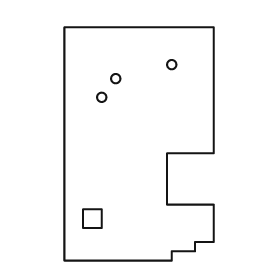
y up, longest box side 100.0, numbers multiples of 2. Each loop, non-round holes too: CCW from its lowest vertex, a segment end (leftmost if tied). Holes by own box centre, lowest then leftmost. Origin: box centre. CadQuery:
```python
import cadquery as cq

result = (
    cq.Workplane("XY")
    .moveTo(-32.0, -50.0)
    .lineTo(14.0, -50.0)
    .lineTo(14.0, -46.0)
    .lineTo(24.0, -46.0)
    .lineTo(24.0, -42.0)
    .lineTo(32.0, -42.0)
    .lineTo(32.0, -26.0)
    .lineTo(12.0, -26.0)
    .lineTo(12.0, -4.0)
    .lineTo(32.0, -4.0)
    .lineTo(32.0, 50.0)
    .lineTo(-32.0, 50.0)
    .close()
    .moveTo(-24.0, -36.0)
    .lineTo(-16.0, -36.0)
    .lineTo(-16.0, -28.0)
    .lineTo(-24.0, -28.0)
    .close()
    .moveTo(-16.0, 20.0)
    .circle(2.0)
    .moveTo(-10.0, 28.0)
    .circle(2.0)
    .moveTo(14.0, 34.0)
    .circle(2.0)
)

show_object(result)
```